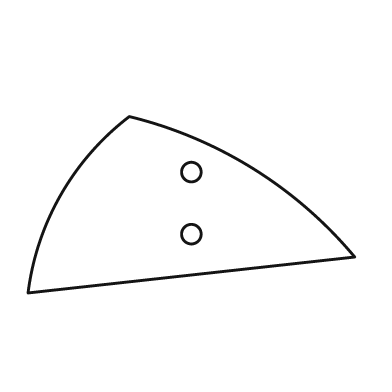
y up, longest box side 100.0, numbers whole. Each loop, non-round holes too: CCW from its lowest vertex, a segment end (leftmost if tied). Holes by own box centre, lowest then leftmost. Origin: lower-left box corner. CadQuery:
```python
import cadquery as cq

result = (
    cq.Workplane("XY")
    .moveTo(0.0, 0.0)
    .lineTo(100.0, 11.0)
    .threePointArc((69.0, 38.0), (31.0, 54.0))
    .threePointArc((10.0, 30.0), (0.0, 0.0))
    .close()
    .moveTo(50.0, 18.0)
    .circle(3.0)
    .moveTo(50.0, 37.0)
    .circle(3.0)
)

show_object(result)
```